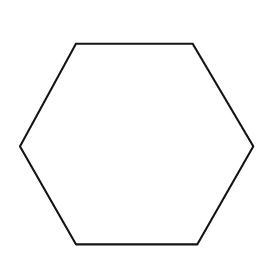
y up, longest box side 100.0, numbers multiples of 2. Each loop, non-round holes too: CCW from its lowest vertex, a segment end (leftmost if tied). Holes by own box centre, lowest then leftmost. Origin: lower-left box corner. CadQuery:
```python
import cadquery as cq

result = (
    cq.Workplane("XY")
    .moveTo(24.0, 0.0)
    .lineTo(76.0, 0.0)
    .lineTo(100.0, 42.0)
    .lineTo(74.0, 86.0)
    .lineTo(24.0, 86.0)
    .lineTo(0.0, 42.0)
    .close()
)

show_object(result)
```